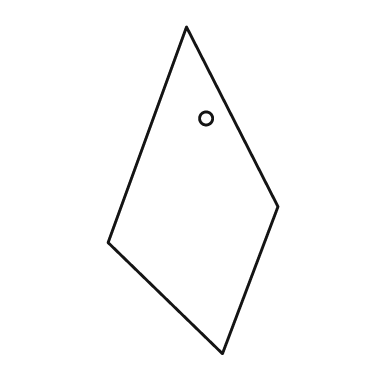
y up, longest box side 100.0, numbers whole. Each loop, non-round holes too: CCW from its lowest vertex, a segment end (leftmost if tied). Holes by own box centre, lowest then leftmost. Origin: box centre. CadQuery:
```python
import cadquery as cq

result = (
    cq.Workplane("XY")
    .moveTo(9.0, -50.0)
    .lineTo(26.0, -5.0)
    .lineTo(-2.0, 50.0)
    .lineTo(-26.0, -16.0)
    .close()
    .moveTo(4.0, 22.0)
    .circle(2.0)
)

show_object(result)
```